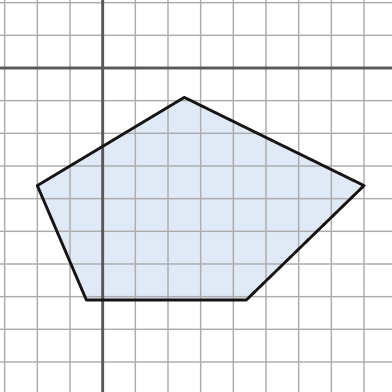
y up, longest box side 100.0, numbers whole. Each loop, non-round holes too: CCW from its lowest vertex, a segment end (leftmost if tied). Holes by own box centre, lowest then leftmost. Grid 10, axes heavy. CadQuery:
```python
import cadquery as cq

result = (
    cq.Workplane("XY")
    .moveTo(-5.0, -71.0)
    .lineTo(44.0, -71.0)
    .lineTo(80.0, -36.0)
    .lineTo(25.0, -9.0)
    .lineTo(-20.0, -36.0)
    .close()
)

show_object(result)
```